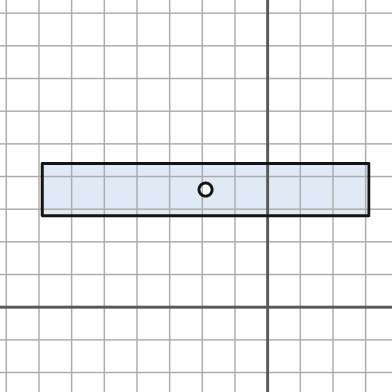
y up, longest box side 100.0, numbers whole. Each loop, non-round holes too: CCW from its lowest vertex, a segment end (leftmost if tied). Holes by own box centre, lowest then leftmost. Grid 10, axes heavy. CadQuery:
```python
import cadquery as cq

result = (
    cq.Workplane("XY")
    .moveTo(-69.0, 28.0)
    .lineTo(31.0, 28.0)
    .lineTo(31.0, 44.0)
    .lineTo(-69.0, 44.0)
    .close()
    .moveTo(-19.0, 36.0)
    .circle(2.0)
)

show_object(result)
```